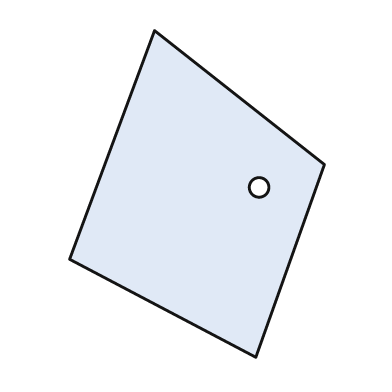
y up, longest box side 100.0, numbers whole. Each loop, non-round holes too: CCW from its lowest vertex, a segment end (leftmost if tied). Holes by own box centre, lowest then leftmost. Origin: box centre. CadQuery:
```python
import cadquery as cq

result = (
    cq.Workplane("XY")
    .moveTo(18.0, -50.0)
    .lineTo(39.0, 9.0)
    .lineTo(-13.0, 50.0)
    .lineTo(-39.0, -20.0)
    .close()
    .moveTo(19.0, 2.0)
    .circle(3.0)
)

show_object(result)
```